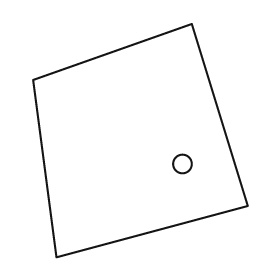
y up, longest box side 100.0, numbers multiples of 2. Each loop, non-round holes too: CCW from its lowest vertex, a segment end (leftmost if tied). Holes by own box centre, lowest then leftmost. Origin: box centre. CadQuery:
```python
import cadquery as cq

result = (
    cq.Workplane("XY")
    .moveTo(-36.0, -50.0)
    .lineTo(46.0, -28.0)
    .lineTo(22.0, 50.0)
    .lineTo(-46.0, 26.0)
    .close()
    .moveTo(18.0, -10.0)
    .circle(4.0)
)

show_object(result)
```